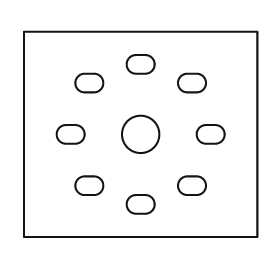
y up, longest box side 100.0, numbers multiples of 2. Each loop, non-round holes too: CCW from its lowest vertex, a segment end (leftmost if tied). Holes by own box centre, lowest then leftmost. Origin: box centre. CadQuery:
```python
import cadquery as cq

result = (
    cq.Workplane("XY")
    .moveTo(-50.0, -44.0)
    .lineTo(50.0, -44.0)
    .lineTo(50.0, 44.0)
    .lineTo(-50.0, 44.0)
    .close()
    .moveTo(-2.0, -34.0)
    .lineTo(2.0, -34.0)
    .threePointArc((6.0, -30.0), (2.0, -26.0))
    .lineTo(-2.0, -26.0)
    .threePointArc((-6.0, -30.0), (-2.0, -34.0))
    .close()
    .moveTo(-24.0, -26.0)
    .lineTo(-20.0, -26.0)
    .threePointArc((-16.0, -22.0), (-20.0, -18.0))
    .lineTo(-24.0, -18.0)
    .threePointArc((-28.0, -22.0), (-24.0, -26.0))
    .close()
    .moveTo(20.0, -26.0)
    .lineTo(24.0, -26.0)
    .threePointArc((28.0, -22.0), (24.0, -18.0))
    .lineTo(20.0, -18.0)
    .threePointArc((16.0, -22.0), (20.0, -26.0))
    .close()
    .moveTo(-32.0, -4.0)
    .lineTo(-28.0, -4.0)
    .threePointArc((-24.0, 0.0), (-28.0, 4.0))
    .lineTo(-32.0, 4.0)
    .threePointArc((-36.0, 0.0), (-32.0, -4.0))
    .close()
    .moveTo(0.0, 0.0)
    .circle(8.0)
    .moveTo(28.0, -4.0)
    .lineTo(32.0, -4.0)
    .threePointArc((36.0, 0.0), (32.0, 4.0))
    .lineTo(28.0, 4.0)
    .threePointArc((24.0, 0.0), (28.0, -4.0))
    .close()
    .moveTo(-24.0, 18.0)
    .lineTo(-20.0, 18.0)
    .threePointArc((-16.0, 22.0), (-20.0, 26.0))
    .lineTo(-24.0, 26.0)
    .threePointArc((-28.0, 22.0), (-24.0, 18.0))
    .close()
    .moveTo(20.0, 18.0)
    .lineTo(24.0, 18.0)
    .threePointArc((28.0, 22.0), (24.0, 26.0))
    .lineTo(20.0, 26.0)
    .threePointArc((16.0, 22.0), (20.0, 18.0))
    .close()
    .moveTo(-2.0, 26.0)
    .lineTo(2.0, 26.0)
    .threePointArc((6.0, 30.0), (2.0, 34.0))
    .lineTo(-2.0, 34.0)
    .threePointArc((-6.0, 30.0), (-2.0, 26.0))
    .close()
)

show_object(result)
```